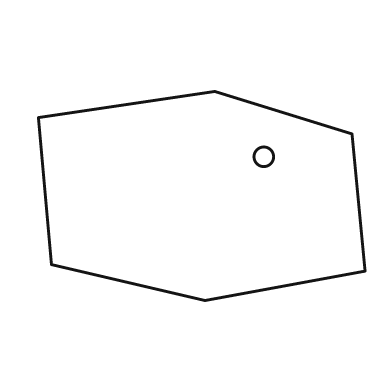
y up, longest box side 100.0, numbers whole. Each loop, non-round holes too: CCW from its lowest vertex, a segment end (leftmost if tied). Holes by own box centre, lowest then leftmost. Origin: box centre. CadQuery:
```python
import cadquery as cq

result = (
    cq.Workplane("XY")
    .moveTo(1.0, -32.0)
    .lineTo(50.0, -23.0)
    .lineTo(46.0, 19.0)
    .lineTo(4.0, 32.0)
    .lineTo(-50.0, 24.0)
    .lineTo(-46.0, -21.0)
    .close()
    .moveTo(19.0, 12.0)
    .circle(3.0)
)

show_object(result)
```